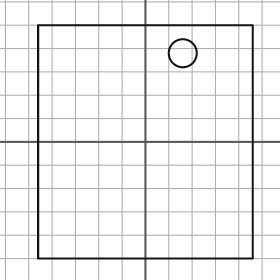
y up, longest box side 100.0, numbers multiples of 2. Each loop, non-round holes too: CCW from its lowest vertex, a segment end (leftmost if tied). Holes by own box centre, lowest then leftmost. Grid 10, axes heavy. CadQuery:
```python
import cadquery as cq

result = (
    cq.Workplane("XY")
    .moveTo(-46.0, -50.0)
    .lineTo(46.0, -50.0)
    .lineTo(46.0, 50.0)
    .lineTo(-46.0, 50.0)
    .close()
    .moveTo(16.0, 38.0)
    .circle(6.0)
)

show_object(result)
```